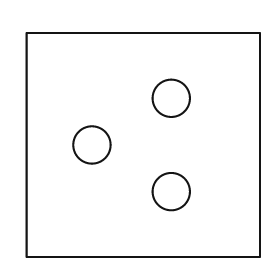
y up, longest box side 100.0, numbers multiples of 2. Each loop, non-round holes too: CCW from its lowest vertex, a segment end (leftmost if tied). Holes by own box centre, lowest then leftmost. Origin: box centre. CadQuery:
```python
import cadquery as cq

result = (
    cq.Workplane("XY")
    .moveTo(-50.0, -48.0)
    .lineTo(50.0, -48.0)
    .lineTo(50.0, 48.0)
    .lineTo(-50.0, 48.0)
    .close()
    .moveTo(12.0, -20.0)
    .circle(8.0)
    .moveTo(-22.0, 0.0)
    .circle(8.0)
    .moveTo(12.0, 20.0)
    .circle(8.0)
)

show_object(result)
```